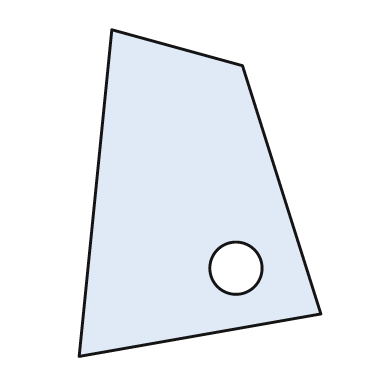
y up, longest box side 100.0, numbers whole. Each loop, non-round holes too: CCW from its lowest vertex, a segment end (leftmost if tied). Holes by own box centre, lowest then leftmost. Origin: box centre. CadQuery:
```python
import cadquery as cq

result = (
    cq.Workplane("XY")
    .moveTo(-37.0, -50.0)
    .lineTo(37.0, -37.0)
    .lineTo(13.0, 39.0)
    .lineTo(-27.0, 50.0)
    .close()
    .moveTo(11.0, -23.0)
    .circle(8.0)
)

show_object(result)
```